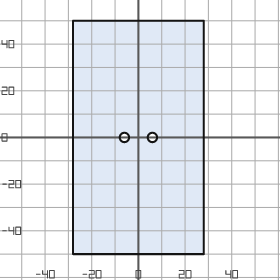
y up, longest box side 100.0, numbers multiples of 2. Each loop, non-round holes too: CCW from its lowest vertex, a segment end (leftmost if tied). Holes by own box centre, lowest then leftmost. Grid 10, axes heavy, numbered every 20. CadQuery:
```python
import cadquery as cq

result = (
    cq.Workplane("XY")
    .moveTo(-28.0, -50.0)
    .lineTo(28.0, -50.0)
    .lineTo(28.0, 50.0)
    .lineTo(-28.0, 50.0)
    .close()
    .moveTo(-6.0, 0.0)
    .circle(2.0)
    .moveTo(6.0, 0.0)
    .circle(2.0)
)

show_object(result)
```